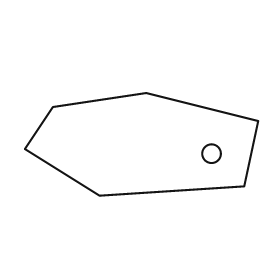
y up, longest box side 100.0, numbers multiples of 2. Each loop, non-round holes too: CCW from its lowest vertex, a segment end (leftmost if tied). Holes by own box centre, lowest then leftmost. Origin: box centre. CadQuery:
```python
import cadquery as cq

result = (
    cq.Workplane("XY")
    .moveTo(-18.0, -22.0)
    .lineTo(44.0, -18.0)
    .lineTo(50.0, 10.0)
    .lineTo(2.0, 22.0)
    .lineTo(-38.0, 16.0)
    .lineTo(-50.0, -2.0)
    .close()
    .moveTo(30.0, -4.0)
    .circle(4.0)
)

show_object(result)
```